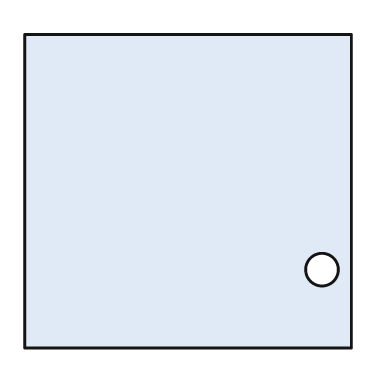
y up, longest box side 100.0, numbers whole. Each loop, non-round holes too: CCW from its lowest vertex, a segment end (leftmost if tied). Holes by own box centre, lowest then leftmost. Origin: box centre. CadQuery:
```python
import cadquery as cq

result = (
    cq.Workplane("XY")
    .moveTo(-50.0, -48.0)
    .lineTo(50.0, -48.0)
    .lineTo(50.0, 48.0)
    .lineTo(-50.0, 48.0)
    .close()
    .moveTo(41.0, -24.0)
    .circle(5.0)
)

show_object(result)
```